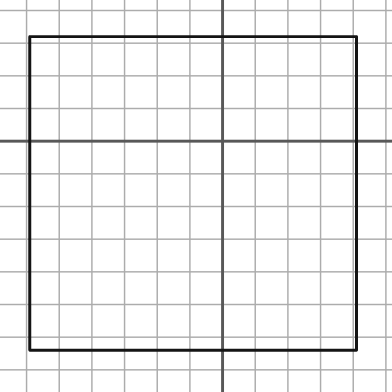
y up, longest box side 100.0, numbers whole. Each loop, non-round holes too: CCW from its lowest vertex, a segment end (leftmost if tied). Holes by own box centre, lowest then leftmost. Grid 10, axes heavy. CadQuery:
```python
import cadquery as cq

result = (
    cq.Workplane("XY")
    .moveTo(-59.0, -64.0)
    .lineTo(41.0, -64.0)
    .lineTo(41.0, 32.0)
    .lineTo(-59.0, 32.0)
    .close()
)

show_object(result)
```